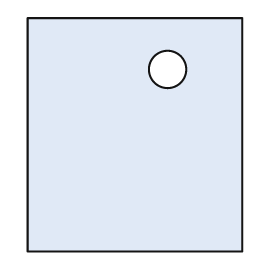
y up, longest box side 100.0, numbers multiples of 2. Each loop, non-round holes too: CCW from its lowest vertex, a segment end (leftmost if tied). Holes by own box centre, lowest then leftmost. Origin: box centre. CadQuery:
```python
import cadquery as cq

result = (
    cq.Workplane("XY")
    .moveTo(-46.0, -50.0)
    .lineTo(46.0, -50.0)
    .lineTo(46.0, 50.0)
    .lineTo(-46.0, 50.0)
    .close()
    .moveTo(14.0, 28.0)
    .circle(8.0)
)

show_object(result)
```